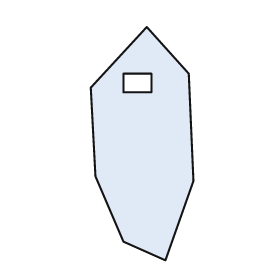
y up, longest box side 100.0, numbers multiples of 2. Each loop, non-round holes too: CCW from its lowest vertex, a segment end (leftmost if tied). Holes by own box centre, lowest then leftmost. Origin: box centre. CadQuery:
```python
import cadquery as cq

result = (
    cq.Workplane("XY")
    .moveTo(10.0, -50.0)
    .lineTo(22.0, -16.0)
    .lineTo(20.0, 30.0)
    .lineTo(2.0, 50.0)
    .lineTo(-22.0, 24.0)
    .lineTo(-20.0, -14.0)
    .lineTo(-8.0, -42.0)
    .close()
    .moveTo(-8.0, 22.0)
    .lineTo(4.0, 22.0)
    .lineTo(4.0, 30.0)
    .lineTo(-8.0, 30.0)
    .close()
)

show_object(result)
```